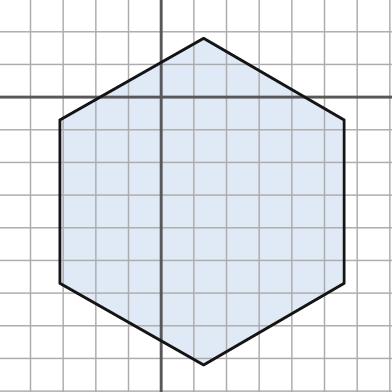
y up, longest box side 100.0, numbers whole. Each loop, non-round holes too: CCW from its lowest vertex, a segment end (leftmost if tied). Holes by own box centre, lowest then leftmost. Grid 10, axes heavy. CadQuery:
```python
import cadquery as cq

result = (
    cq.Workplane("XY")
    .moveTo(13.0, -82.0)
    .lineTo(56.0, -57.0)
    .lineTo(56.0, -7.0)
    .lineTo(13.0, 18.0)
    .lineTo(-31.0, -7.0)
    .lineTo(-31.0, -57.0)
    .close()
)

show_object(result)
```